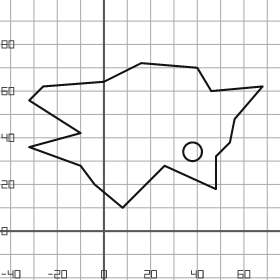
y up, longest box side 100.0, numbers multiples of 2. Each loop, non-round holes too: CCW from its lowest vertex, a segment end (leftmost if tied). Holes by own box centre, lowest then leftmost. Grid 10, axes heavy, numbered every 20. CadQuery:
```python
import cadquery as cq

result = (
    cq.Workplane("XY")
    .moveTo(8.0, 10.0)
    .lineTo(26.0, 28.0)
    .lineTo(48.0, 18.0)
    .lineTo(48.0, 32.0)
    .lineTo(54.0, 38.0)
    .lineTo(56.0, 48.0)
    .lineTo(68.0, 62.0)
    .lineTo(46.0, 60.0)
    .lineTo(40.0, 70.0)
    .lineTo(16.0, 72.0)
    .lineTo(0.0, 64.0)
    .lineTo(-26.0, 62.0)
    .lineTo(-32.0, 56.0)
    .lineTo(-10.0, 42.0)
    .lineTo(-32.0, 36.0)
    .lineTo(-10.0, 28.0)
    .lineTo(-4.0, 20.0)
    .close()
    .moveTo(38.0, 34.0)
    .circle(4.0)
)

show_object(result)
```